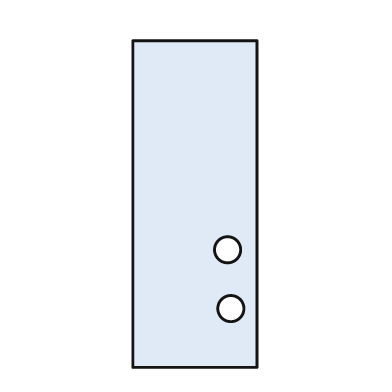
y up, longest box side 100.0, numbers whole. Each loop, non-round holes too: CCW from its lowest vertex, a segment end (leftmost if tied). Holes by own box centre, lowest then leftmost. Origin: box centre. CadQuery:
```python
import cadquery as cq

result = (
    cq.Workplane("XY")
    .moveTo(-19.0, -50.0)
    .lineTo(19.0, -50.0)
    .lineTo(19.0, 50.0)
    .lineTo(-19.0, 50.0)
    .close()
    .moveTo(11.0, -32.0)
    .circle(4.0)
    .moveTo(10.0, -14.0)
    .circle(4.0)
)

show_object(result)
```